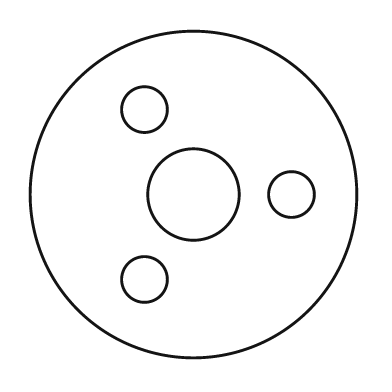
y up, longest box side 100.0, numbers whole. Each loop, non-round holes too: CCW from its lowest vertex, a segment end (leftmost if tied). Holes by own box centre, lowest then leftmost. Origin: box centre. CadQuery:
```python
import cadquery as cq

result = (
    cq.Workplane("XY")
    .moveTo(0.0, 0.0)
    .circle(50.0)
    .moveTo(-15.0, -26.0)
    .circle(7.0)
    .moveTo(0.0, 0.0)
    .circle(14.0)
    .moveTo(30.0, 0.0)
    .circle(7.0)
    .moveTo(-15.0, 26.0)
    .circle(7.0)
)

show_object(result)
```